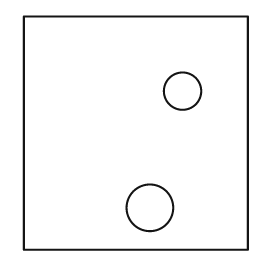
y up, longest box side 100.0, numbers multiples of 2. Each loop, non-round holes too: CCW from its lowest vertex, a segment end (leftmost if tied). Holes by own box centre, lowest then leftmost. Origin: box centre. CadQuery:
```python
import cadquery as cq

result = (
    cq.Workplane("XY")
    .moveTo(-48.0, -50.0)
    .lineTo(48.0, -50.0)
    .lineTo(48.0, 50.0)
    .lineTo(-48.0, 50.0)
    .close()
    .moveTo(6.0, -32.0)
    .circle(10.0)
    .moveTo(20.0, 18.0)
    .circle(8.0)
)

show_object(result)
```